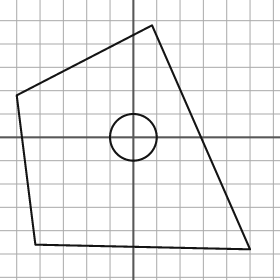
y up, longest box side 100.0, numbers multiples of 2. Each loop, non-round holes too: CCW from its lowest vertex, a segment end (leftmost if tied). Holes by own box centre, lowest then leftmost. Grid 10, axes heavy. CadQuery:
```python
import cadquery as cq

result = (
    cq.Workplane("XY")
    .moveTo(50.0, -48.0)
    .lineTo(8.0, 48.0)
    .lineTo(-50.0, 18.0)
    .lineTo(-42.0, -46.0)
    .close()
    .moveTo(0.0, 0.0)
    .circle(10.0)
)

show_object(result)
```